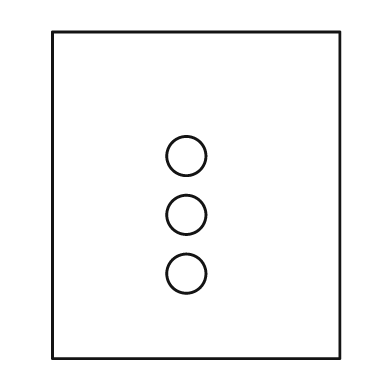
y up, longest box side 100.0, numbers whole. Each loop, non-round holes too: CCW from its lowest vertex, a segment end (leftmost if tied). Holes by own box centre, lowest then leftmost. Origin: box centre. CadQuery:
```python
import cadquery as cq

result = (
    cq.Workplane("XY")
    .moveTo(-44.0, -50.0)
    .lineTo(44.0, -50.0)
    .lineTo(44.0, 50.0)
    .lineTo(-44.0, 50.0)
    .close()
    .moveTo(-3.0, -24.0)
    .circle(6.0)
    .moveTo(-3.0, -6.0)
    .circle(6.0)
    .moveTo(-3.0, 12.0)
    .circle(6.0)
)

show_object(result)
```